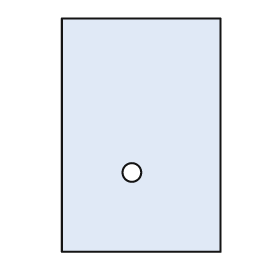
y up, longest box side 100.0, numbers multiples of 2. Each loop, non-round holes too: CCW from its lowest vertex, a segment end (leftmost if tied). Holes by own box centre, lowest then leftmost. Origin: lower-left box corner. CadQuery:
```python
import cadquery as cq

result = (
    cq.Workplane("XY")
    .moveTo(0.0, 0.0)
    .lineTo(68.0, 0.0)
    .lineTo(68.0, 100.0)
    .lineTo(0.0, 100.0)
    .close()
    .moveTo(30.0, 34.0)
    .circle(4.0)
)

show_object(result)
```